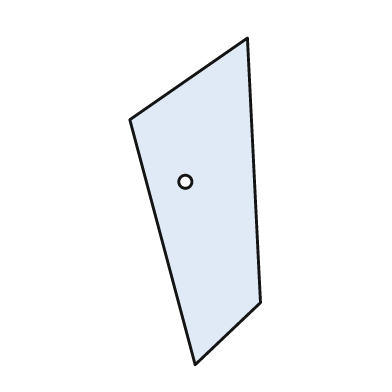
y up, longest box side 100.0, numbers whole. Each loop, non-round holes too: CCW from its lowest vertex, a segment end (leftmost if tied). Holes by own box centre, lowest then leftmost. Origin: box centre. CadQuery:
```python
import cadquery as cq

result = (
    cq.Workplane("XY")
    .moveTo(0.0, -50.0)
    .lineTo(20.0, -31.0)
    .lineTo(16.0, 50.0)
    .lineTo(-20.0, 25.0)
    .close()
    .moveTo(-3.0, 6.0)
    .circle(2.0)
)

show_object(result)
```